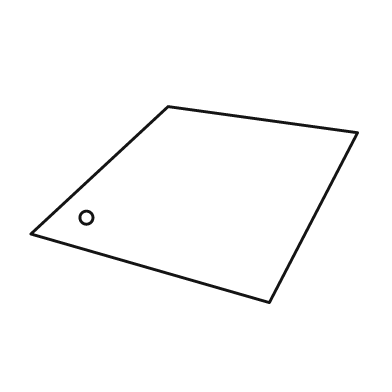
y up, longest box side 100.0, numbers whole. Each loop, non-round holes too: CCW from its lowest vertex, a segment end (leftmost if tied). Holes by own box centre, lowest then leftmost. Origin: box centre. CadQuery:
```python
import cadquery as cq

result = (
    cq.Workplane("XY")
    .moveTo(23.0, -30.0)
    .lineTo(50.0, 22.0)
    .lineTo(-8.0, 30.0)
    .lineTo(-50.0, -9.0)
    .close()
    .moveTo(-33.0, -4.0)
    .circle(2.0)
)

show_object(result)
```